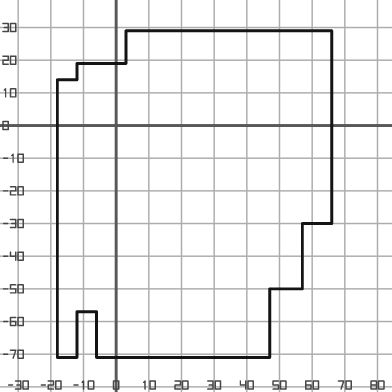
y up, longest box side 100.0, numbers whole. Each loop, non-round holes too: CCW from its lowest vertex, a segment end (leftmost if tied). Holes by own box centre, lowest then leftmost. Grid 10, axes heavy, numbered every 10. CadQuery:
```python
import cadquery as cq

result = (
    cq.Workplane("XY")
    .moveTo(-18.0, -71.0)
    .lineTo(-12.0, -71.0)
    .lineTo(-12.0, -57.0)
    .lineTo(-6.0, -57.0)
    .lineTo(-6.0, -71.0)
    .lineTo(47.0, -71.0)
    .lineTo(47.0, -50.0)
    .lineTo(57.0, -50.0)
    .lineTo(57.0, -30.0)
    .lineTo(66.0, -30.0)
    .lineTo(66.0, 29.0)
    .lineTo(3.0, 29.0)
    .lineTo(3.0, 19.0)
    .lineTo(-12.0, 19.0)
    .lineTo(-12.0, 14.0)
    .lineTo(-18.0, 14.0)
    .close()
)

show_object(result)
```